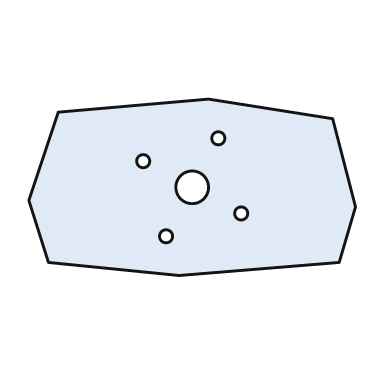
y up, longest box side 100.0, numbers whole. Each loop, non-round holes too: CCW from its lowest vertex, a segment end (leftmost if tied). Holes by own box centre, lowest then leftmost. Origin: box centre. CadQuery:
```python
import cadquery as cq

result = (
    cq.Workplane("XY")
    .moveTo(-4.0, -27.0)
    .lineTo(45.0, -23.0)
    .lineTo(50.0, -6.0)
    .lineTo(43.0, 21.0)
    .lineTo(5.0, 27.0)
    .lineTo(-41.0, 23.0)
    .lineTo(-50.0, -4.0)
    .lineTo(-44.0, -23.0)
    .close()
    .moveTo(-8.0, -15.0)
    .circle(2.0)
    .moveTo(15.0, -8.0)
    .circle(2.0)
    .moveTo(0.0, 0.0)
    .circle(5.0)
    .moveTo(-15.0, 8.0)
    .circle(2.0)
    .moveTo(8.0, 15.0)
    .circle(2.0)
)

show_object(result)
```